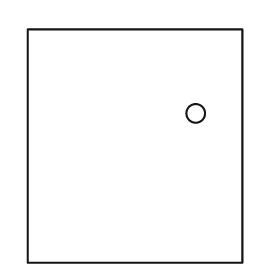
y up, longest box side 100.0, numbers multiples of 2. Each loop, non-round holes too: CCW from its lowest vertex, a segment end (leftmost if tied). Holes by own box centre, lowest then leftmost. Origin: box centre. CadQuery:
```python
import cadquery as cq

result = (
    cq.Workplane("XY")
    .moveTo(-46.0, -50.0)
    .lineTo(46.0, -50.0)
    .lineTo(46.0, 50.0)
    .lineTo(-46.0, 50.0)
    .close()
    .moveTo(26.0, 14.0)
    .circle(4.0)
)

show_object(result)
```